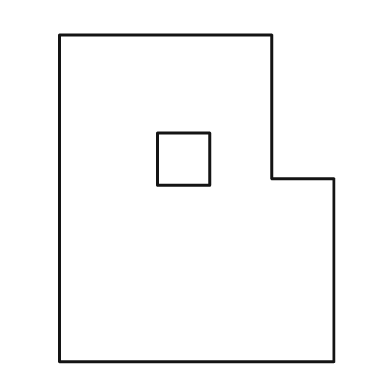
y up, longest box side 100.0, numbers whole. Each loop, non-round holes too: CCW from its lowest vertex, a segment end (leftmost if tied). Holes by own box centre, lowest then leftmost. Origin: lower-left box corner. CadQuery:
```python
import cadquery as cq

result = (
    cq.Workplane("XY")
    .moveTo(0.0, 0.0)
    .lineTo(84.0, 0.0)
    .lineTo(84.0, 56.0)
    .lineTo(65.0, 56.0)
    .lineTo(65.0, 100.0)
    .lineTo(0.0, 100.0)
    .close()
    .moveTo(30.0, 54.0)
    .lineTo(46.0, 54.0)
    .lineTo(46.0, 70.0)
    .lineTo(30.0, 70.0)
    .close()
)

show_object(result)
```